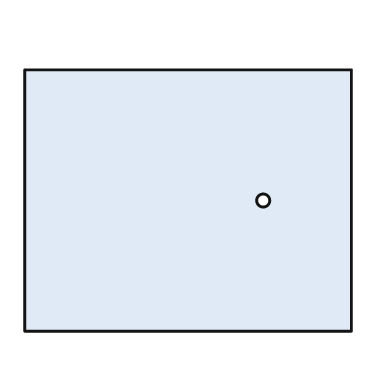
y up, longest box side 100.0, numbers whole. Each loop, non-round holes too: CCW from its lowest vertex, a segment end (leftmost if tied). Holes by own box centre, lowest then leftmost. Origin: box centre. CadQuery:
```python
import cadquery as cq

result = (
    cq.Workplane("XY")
    .moveTo(-50.0, -40.0)
    .lineTo(50.0, -40.0)
    .lineTo(50.0, 40.0)
    .lineTo(-50.0, 40.0)
    .close()
    .moveTo(23.0, 0.0)
    .circle(2.0)
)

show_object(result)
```